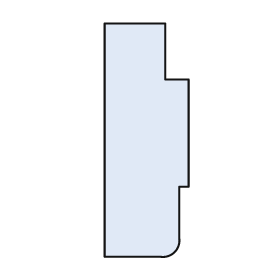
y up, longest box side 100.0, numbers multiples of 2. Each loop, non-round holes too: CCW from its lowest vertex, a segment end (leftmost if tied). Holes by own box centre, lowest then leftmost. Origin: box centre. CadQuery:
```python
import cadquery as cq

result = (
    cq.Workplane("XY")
    .moveTo(-18.0, -50.0)
    .lineTo(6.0, -50.0)
    .threePointArc((12.0, -48.0), (14.0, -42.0))
    .lineTo(14.0, -20.0)
    .lineTo(18.0, -20.0)
    .lineTo(18.0, 26.0)
    .lineTo(8.0, 26.0)
    .lineTo(8.0, 50.0)
    .lineTo(-18.0, 50.0)
    .close()
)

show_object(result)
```